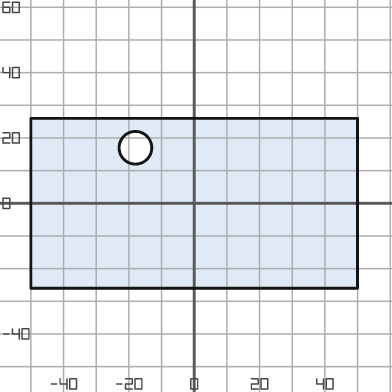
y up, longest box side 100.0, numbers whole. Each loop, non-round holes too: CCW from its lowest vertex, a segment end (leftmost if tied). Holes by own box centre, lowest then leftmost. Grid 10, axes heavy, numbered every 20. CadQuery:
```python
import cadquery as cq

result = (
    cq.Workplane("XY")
    .moveTo(-50.0, -26.0)
    .lineTo(50.0, -26.0)
    .lineTo(50.0, 26.0)
    .lineTo(-50.0, 26.0)
    .close()
    .moveTo(-18.0, 17.0)
    .circle(5.0)
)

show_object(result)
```